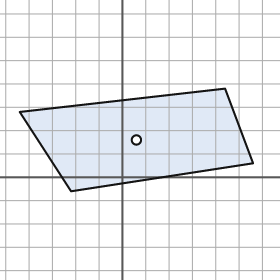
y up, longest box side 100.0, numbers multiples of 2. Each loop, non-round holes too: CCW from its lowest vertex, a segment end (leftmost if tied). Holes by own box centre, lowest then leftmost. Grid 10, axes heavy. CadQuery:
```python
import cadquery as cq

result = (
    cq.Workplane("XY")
    .moveTo(-22.0, -6.0)
    .lineTo(56.0, 6.0)
    .lineTo(44.0, 38.0)
    .lineTo(-44.0, 28.0)
    .close()
    .moveTo(6.0, 16.0)
    .circle(2.0)
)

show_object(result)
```